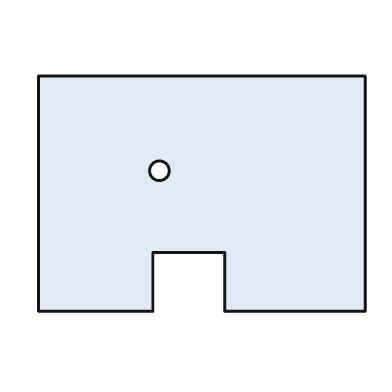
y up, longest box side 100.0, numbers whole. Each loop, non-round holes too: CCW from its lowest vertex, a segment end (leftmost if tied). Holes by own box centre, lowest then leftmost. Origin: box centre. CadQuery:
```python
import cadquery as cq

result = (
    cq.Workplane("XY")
    .moveTo(-50.0, -36.0)
    .lineTo(-15.0, -36.0)
    .lineTo(-15.0, -18.0)
    .lineTo(7.0, -18.0)
    .lineTo(7.0, -36.0)
    .lineTo(50.0, -36.0)
    .lineTo(50.0, 36.0)
    .lineTo(-50.0, 36.0)
    .close()
    .moveTo(-13.0, 7.0)
    .circle(3.0)
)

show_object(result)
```